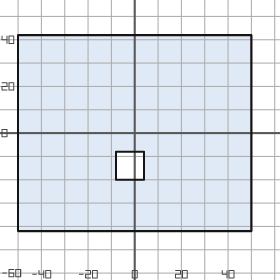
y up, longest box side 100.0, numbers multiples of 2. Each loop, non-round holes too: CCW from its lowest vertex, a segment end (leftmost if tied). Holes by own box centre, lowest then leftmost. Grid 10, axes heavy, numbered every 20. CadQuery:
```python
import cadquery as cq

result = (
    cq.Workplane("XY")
    .moveTo(-50.0, -42.0)
    .lineTo(50.0, -42.0)
    .lineTo(50.0, 42.0)
    .lineTo(-50.0, 42.0)
    .close()
    .moveTo(-8.0, -20.0)
    .lineTo(4.0, -20.0)
    .lineTo(4.0, -8.0)
    .lineTo(-8.0, -8.0)
    .close()
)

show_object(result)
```